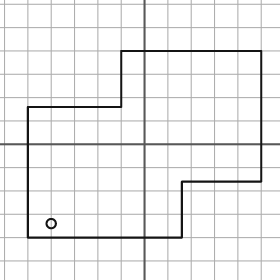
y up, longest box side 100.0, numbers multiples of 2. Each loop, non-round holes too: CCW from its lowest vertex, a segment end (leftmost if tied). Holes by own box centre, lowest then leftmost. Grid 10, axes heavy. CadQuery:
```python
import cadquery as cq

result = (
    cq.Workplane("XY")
    .moveTo(-50.0, -40.0)
    .lineTo(16.0, -40.0)
    .lineTo(16.0, -16.0)
    .lineTo(50.0, -16.0)
    .lineTo(50.0, 40.0)
    .lineTo(-10.0, 40.0)
    .lineTo(-10.0, 16.0)
    .lineTo(-50.0, 16.0)
    .close()
    .moveTo(-40.0, -34.0)
    .circle(2.0)
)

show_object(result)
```